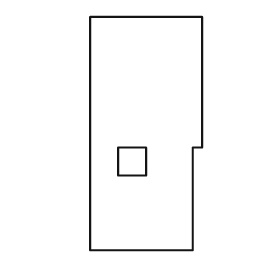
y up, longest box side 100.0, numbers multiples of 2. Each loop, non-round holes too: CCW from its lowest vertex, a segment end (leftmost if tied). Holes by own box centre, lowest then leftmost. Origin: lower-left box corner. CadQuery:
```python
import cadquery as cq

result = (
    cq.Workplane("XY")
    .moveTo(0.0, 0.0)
    .lineTo(44.0, 0.0)
    .lineTo(44.0, 44.0)
    .lineTo(48.0, 44.0)
    .lineTo(48.0, 100.0)
    .lineTo(0.0, 100.0)
    .close()
    .moveTo(12.0, 32.0)
    .lineTo(24.0, 32.0)
    .lineTo(24.0, 44.0)
    .lineTo(12.0, 44.0)
    .close()
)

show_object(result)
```